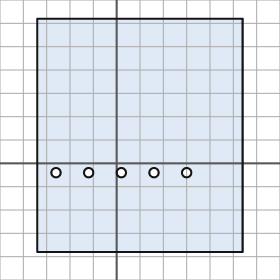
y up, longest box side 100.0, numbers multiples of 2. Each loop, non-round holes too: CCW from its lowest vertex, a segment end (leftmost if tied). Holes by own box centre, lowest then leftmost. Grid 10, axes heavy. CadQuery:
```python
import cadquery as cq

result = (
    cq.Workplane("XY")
    .moveTo(-34.0, -38.0)
    .lineTo(54.0, -38.0)
    .lineTo(54.0, 62.0)
    .lineTo(-34.0, 62.0)
    .close()
    .moveTo(-26.0, -4.0)
    .circle(2.0)
    .moveTo(-12.0, -4.0)
    .circle(2.0)
    .moveTo(2.0, -4.0)
    .circle(2.0)
    .moveTo(16.0, -4.0)
    .circle(2.0)
    .moveTo(30.0, -4.0)
    .circle(2.0)
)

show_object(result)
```